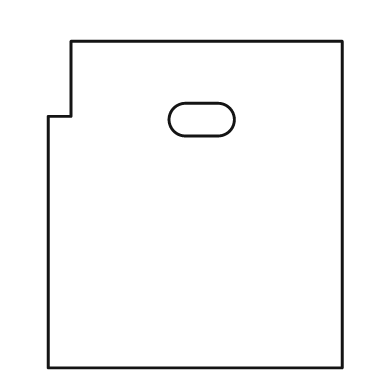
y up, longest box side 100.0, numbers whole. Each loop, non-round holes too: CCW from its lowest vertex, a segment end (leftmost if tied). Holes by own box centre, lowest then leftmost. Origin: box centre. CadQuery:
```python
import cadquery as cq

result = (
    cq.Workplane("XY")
    .moveTo(-45.0, -50.0)
    .lineTo(45.0, -50.0)
    .lineTo(45.0, 50.0)
    .lineTo(-38.0, 50.0)
    .lineTo(-38.0, 27.0)
    .lineTo(-45.0, 27.0)
    .close()
    .moveTo(-3.0, 21.0)
    .lineTo(7.0, 21.0)
    .threePointArc((12.0, 26.0), (7.0, 31.0))
    .lineTo(-3.0, 31.0)
    .threePointArc((-8.0, 26.0), (-3.0, 21.0))
    .close()
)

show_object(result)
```